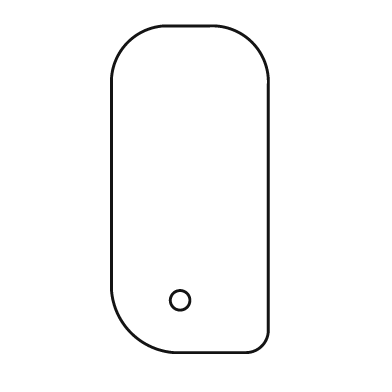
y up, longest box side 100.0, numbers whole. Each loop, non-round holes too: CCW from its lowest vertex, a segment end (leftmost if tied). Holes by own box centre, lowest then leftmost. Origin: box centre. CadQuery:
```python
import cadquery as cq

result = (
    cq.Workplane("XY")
    .moveTo(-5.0, -50.0)
    .lineTo(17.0, -50.0)
    .threePointArc((22.0, -48.0), (24.0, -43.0))
    .lineTo(24.0, 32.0)
    .threePointArc((19.0, 45.0), (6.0, 50.0))
    .lineTo(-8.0, 50.0)
    .threePointArc((-19.0, 45.0), (-24.0, 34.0))
    .lineTo(-24.0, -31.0)
    .threePointArc((-18.0, -44.0), (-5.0, -50.0))
    .close()
    .moveTo(-3.0, -34.0)
    .circle(3.0)
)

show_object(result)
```